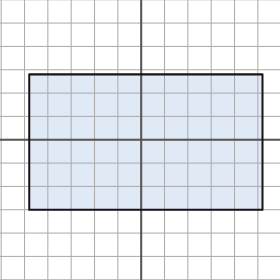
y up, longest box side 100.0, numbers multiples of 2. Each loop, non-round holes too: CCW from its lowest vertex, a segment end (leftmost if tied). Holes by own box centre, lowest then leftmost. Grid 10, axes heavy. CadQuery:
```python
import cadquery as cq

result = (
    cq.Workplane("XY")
    .moveTo(-48.0, -30.0)
    .lineTo(52.0, -30.0)
    .lineTo(52.0, 28.0)
    .lineTo(-48.0, 28.0)
    .close()
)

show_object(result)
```